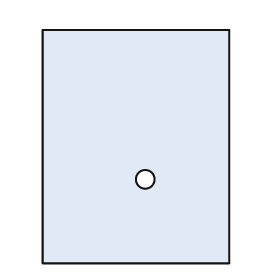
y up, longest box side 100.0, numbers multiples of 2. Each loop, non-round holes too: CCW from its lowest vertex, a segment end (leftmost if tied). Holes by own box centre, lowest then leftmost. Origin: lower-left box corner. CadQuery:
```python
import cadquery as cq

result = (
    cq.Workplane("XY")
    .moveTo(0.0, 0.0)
    .lineTo(80.0, 0.0)
    .lineTo(80.0, 100.0)
    .lineTo(0.0, 100.0)
    .close()
    .moveTo(44.0, 36.0)
    .circle(4.0)
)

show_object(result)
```